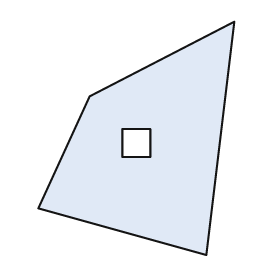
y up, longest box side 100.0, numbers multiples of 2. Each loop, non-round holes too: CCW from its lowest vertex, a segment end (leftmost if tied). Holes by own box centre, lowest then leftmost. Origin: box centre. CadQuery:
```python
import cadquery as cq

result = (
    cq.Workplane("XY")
    .moveTo(30.0, -50.0)
    .lineTo(42.0, 50.0)
    .lineTo(-20.0, 18.0)
    .lineTo(-42.0, -30.0)
    .close()
    .moveTo(-6.0, -8.0)
    .lineTo(6.0, -8.0)
    .lineTo(6.0, 4.0)
    .lineTo(-6.0, 4.0)
    .close()
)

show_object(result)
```